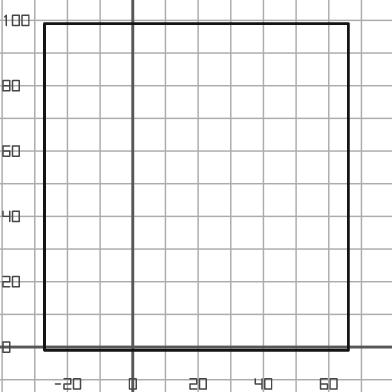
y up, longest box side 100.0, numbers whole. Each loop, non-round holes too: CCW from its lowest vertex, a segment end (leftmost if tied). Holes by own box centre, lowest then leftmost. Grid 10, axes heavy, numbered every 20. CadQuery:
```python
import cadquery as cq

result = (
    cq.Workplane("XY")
    .moveTo(-27.0, -1.0)
    .lineTo(66.0, -1.0)
    .lineTo(66.0, 99.0)
    .lineTo(-27.0, 99.0)
    .close()
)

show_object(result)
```